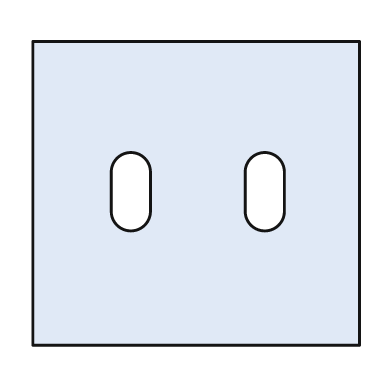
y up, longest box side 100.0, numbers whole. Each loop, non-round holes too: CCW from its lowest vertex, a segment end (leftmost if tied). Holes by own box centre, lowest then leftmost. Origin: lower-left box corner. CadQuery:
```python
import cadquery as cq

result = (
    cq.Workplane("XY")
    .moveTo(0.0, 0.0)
    .lineTo(100.0, 0.0)
    .lineTo(100.0, 93.0)
    .lineTo(0.0, 93.0)
    .close()
    .moveTo(24.0, 41.0)
    .threePointArc((30.0, 35.0), (36.0, 41.0))
    .lineTo(36.0, 53.0)
    .threePointArc((30.0, 59.0), (24.0, 53.0))
    .close()
    .moveTo(65.0, 41.0)
    .threePointArc((71.0, 35.0), (77.0, 41.0))
    .lineTo(77.0, 53.0)
    .threePointArc((71.0, 59.0), (65.0, 53.0))
    .close()
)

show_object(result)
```